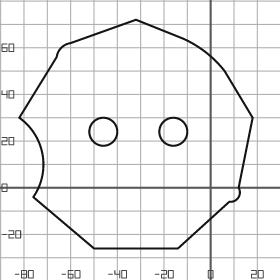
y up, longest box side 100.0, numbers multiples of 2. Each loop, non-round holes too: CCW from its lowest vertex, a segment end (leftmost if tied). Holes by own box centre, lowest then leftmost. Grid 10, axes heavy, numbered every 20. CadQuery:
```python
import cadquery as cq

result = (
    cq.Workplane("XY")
    .moveTo(-50.0, -26.0)
    .lineTo(-14.0, -26.0)
    .lineTo(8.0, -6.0)
    .threePointArc((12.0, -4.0), (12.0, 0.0))
    .lineTo(18.0, 30.0)
    .lineTo(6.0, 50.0)
    .threePointArc((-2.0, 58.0), (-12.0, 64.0))
    .lineTo(-32.0, 72.0)
    .lineTo(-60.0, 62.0)
    .threePointArc((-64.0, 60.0), (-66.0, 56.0))
    .lineTo(-82.0, 30.0)
    .threePointArc((-72.0, 14.0), (-76.0, -4.0))
    .close()
    .moveTo(-46.0, 24.0)
    .circle(6.0)
    .moveTo(-16.0, 24.0)
    .circle(6.0)
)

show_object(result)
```